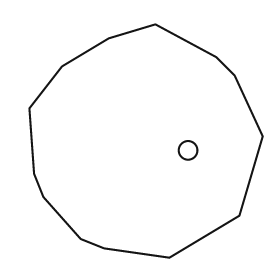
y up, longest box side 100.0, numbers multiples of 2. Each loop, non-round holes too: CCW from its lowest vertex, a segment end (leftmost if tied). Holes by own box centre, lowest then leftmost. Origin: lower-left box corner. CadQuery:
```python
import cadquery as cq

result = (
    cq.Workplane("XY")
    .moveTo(60.0, 0.0)
    .lineTo(90.0, 18.0)
    .lineTo(100.0, 52.0)
    .lineTo(88.0, 78.0)
    .lineTo(80.0, 86.0)
    .lineTo(54.0, 100.0)
    .lineTo(34.0, 94.0)
    .lineTo(14.0, 82.0)
    .lineTo(0.0, 64.0)
    .lineTo(2.0, 36.0)
    .lineTo(6.0, 26.0)
    .lineTo(22.0, 8.0)
    .lineTo(32.0, 4.0)
    .close()
    .moveTo(68.0, 46.0)
    .circle(4.0)
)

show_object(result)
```